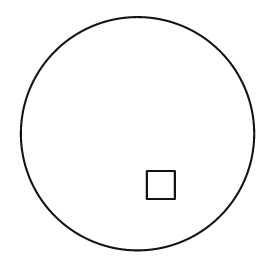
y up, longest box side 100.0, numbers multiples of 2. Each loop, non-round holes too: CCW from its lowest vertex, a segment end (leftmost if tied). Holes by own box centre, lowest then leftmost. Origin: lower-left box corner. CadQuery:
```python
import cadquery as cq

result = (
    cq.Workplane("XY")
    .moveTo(50.0, 50.0)
    .circle(50.0)
    .moveTo(54.0, 22.0)
    .lineTo(66.0, 22.0)
    .lineTo(66.0, 34.0)
    .lineTo(54.0, 34.0)
    .close()
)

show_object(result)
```